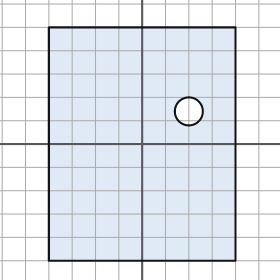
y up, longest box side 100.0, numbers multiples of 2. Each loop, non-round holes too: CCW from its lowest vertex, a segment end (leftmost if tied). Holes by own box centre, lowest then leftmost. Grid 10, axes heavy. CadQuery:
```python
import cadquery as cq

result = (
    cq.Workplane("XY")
    .moveTo(-40.0, -50.0)
    .lineTo(40.0, -50.0)
    .lineTo(40.0, 50.0)
    .lineTo(-40.0, 50.0)
    .close()
    .moveTo(20.0, 14.0)
    .circle(6.0)
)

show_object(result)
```